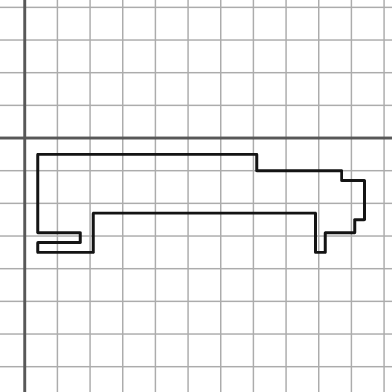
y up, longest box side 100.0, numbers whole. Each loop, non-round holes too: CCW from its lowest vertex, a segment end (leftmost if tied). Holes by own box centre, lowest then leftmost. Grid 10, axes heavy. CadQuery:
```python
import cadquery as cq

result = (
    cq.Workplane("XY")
    .moveTo(4.0, -35.0)
    .lineTo(21.0, -35.0)
    .lineTo(21.0, -23.0)
    .lineTo(89.0, -23.0)
    .lineTo(89.0, -35.0)
    .lineTo(92.0, -35.0)
    .lineTo(92.0, -29.0)
    .lineTo(101.0, -29.0)
    .lineTo(101.0, -25.0)
    .lineTo(104.0, -25.0)
    .lineTo(104.0, -13.0)
    .lineTo(97.0, -13.0)
    .lineTo(97.0, -10.0)
    .lineTo(71.0, -10.0)
    .lineTo(71.0, -5.0)
    .lineTo(4.0, -5.0)
    .lineTo(4.0, -29.0)
    .lineTo(17.0, -29.0)
    .lineTo(17.0, -32.0)
    .lineTo(4.0, -32.0)
    .close()
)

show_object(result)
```